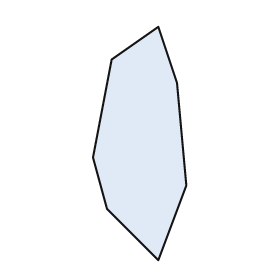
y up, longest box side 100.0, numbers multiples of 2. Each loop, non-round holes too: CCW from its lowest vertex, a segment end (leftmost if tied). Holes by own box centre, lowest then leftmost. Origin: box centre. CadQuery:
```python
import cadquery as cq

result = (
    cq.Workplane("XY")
    .moveTo(8.0, -50.0)
    .lineTo(20.0, -18.0)
    .lineTo(16.0, 26.0)
    .lineTo(8.0, 50.0)
    .lineTo(-12.0, 36.0)
    .lineTo(-20.0, -6.0)
    .lineTo(-14.0, -28.0)
    .close()
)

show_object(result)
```